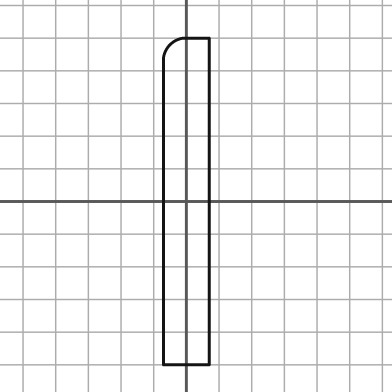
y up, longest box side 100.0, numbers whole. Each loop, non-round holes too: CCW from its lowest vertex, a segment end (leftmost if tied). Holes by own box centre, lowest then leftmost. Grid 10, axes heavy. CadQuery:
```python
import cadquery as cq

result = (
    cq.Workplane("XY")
    .moveTo(-7.0, -50.0)
    .lineTo(7.0, -50.0)
    .lineTo(7.0, 50.0)
    .lineTo(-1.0, 50.0)
    .threePointArc((-5.0, 48.0), (-7.0, 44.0))
    .close()
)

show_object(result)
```